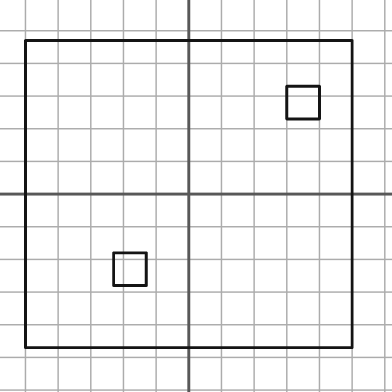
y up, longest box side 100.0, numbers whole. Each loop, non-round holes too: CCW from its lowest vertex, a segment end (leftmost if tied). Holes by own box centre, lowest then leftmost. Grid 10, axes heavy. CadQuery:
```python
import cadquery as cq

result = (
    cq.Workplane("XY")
    .moveTo(-50.0, -47.0)
    .lineTo(50.0, -47.0)
    .lineTo(50.0, 47.0)
    .lineTo(-50.0, 47.0)
    .close()
    .moveTo(-23.0, -28.0)
    .lineTo(-13.0, -28.0)
    .lineTo(-13.0, -18.0)
    .lineTo(-23.0, -18.0)
    .close()
    .moveTo(30.0, 23.0)
    .lineTo(40.0, 23.0)
    .lineTo(40.0, 33.0)
    .lineTo(30.0, 33.0)
    .close()
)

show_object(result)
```